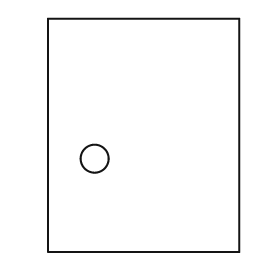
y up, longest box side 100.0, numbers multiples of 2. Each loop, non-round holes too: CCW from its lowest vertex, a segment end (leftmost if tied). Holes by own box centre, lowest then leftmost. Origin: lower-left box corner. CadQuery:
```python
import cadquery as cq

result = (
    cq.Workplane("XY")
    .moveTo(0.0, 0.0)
    .lineTo(82.0, 0.0)
    .lineTo(82.0, 100.0)
    .lineTo(0.0, 100.0)
    .close()
    .moveTo(20.0, 40.0)
    .circle(6.0)
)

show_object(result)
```